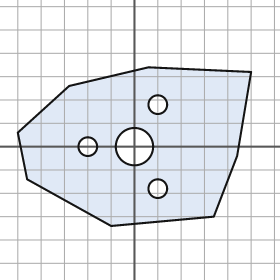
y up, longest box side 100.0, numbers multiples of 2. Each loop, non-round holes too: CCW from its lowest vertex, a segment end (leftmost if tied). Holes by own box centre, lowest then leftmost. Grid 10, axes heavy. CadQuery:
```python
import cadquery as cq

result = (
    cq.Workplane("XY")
    .moveTo(-10.0, -34.0)
    .lineTo(34.0, -30.0)
    .lineTo(44.0, -4.0)
    .lineTo(50.0, 32.0)
    .lineTo(6.0, 34.0)
    .lineTo(-28.0, 26.0)
    .lineTo(-50.0, 6.0)
    .lineTo(-46.0, -14.0)
    .close()
    .moveTo(10.0, -18.0)
    .circle(4.0)
    .moveTo(-20.0, 0.0)
    .circle(4.0)
    .moveTo(0.0, 0.0)
    .circle(8.0)
    .moveTo(10.0, 18.0)
    .circle(4.0)
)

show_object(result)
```